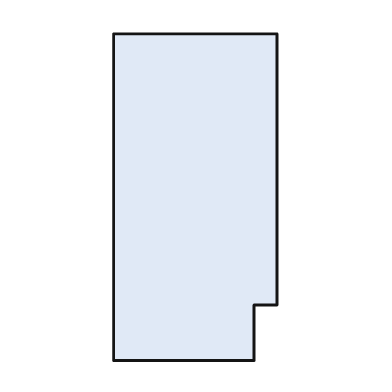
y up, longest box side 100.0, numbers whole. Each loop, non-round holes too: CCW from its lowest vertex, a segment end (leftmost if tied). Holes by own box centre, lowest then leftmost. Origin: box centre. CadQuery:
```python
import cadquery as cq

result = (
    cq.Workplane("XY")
    .moveTo(-25.0, -50.0)
    .lineTo(18.0, -50.0)
    .lineTo(18.0, -33.0)
    .lineTo(25.0, -33.0)
    .lineTo(25.0, 50.0)
    .lineTo(-25.0, 50.0)
    .close()
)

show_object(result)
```